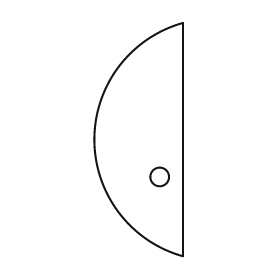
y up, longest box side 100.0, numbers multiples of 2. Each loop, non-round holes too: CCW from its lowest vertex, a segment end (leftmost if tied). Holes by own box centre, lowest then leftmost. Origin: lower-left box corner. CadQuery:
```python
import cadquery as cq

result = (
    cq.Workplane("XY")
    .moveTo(38.0, 0.0)
    .lineTo(38.0, 100.0)
    .threePointArc((0.0, 50.0), (38.0, 0.0))
    .close()
    .moveTo(28.0, 34.0)
    .circle(4.0)
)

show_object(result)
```